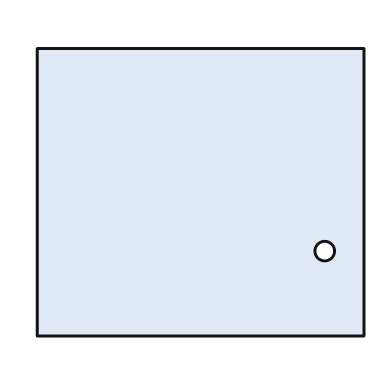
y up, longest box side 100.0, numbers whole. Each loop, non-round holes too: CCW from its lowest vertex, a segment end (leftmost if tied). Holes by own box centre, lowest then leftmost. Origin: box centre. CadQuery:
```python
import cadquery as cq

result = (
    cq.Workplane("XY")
    .moveTo(-50.0, -44.0)
    .lineTo(50.0, -44.0)
    .lineTo(50.0, 44.0)
    .lineTo(-50.0, 44.0)
    .close()
    .moveTo(38.0, -18.0)
    .circle(3.0)
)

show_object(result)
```